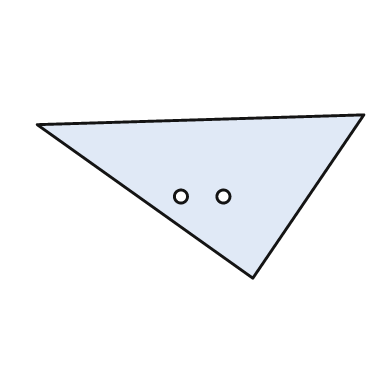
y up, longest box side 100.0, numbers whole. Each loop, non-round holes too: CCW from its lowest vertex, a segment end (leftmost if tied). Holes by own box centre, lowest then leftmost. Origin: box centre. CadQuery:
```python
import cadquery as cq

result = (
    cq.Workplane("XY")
    .moveTo(16.0, -25.0)
    .lineTo(50.0, 25.0)
    .lineTo(-50.0, 22.0)
    .close()
    .moveTo(-6.0, 0.0)
    .circle(2.0)
    .moveTo(7.0, 0.0)
    .circle(2.0)
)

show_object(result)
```